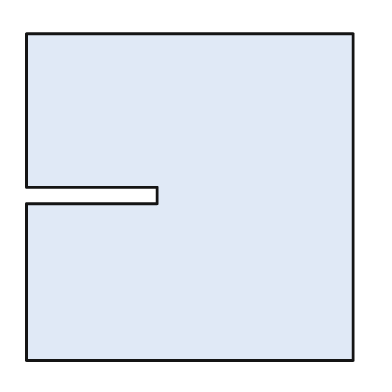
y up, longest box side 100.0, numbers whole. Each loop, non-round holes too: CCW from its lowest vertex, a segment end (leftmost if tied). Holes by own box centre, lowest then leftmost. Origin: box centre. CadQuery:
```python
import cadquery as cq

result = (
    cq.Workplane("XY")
    .moveTo(-50.0, -50.0)
    .lineTo(50.0, -50.0)
    .lineTo(50.0, 50.0)
    .lineTo(-50.0, 50.0)
    .lineTo(-50.0, 3.0)
    .lineTo(-10.0, 3.0)
    .lineTo(-10.0, -2.0)
    .lineTo(-50.0, -2.0)
    .close()
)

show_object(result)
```